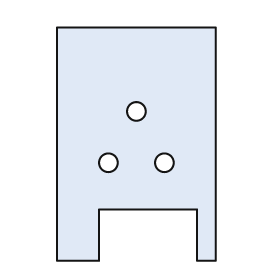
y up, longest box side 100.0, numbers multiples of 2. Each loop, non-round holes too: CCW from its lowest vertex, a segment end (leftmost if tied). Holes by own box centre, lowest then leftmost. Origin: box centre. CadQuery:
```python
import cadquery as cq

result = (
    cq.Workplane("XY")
    .moveTo(-34.0, -50.0)
    .lineTo(-16.0, -50.0)
    .lineTo(-16.0, -28.0)
    .lineTo(26.0, -28.0)
    .lineTo(26.0, -50.0)
    .lineTo(34.0, -50.0)
    .lineTo(34.0, 50.0)
    .lineTo(-34.0, 50.0)
    .close()
    .moveTo(-12.0, -8.0)
    .circle(4.0)
    .moveTo(12.0, -8.0)
    .circle(4.0)
    .moveTo(0.0, 14.0)
    .circle(4.0)
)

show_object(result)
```